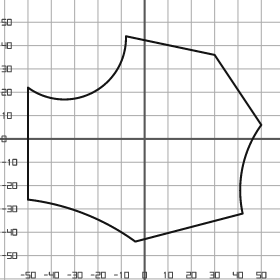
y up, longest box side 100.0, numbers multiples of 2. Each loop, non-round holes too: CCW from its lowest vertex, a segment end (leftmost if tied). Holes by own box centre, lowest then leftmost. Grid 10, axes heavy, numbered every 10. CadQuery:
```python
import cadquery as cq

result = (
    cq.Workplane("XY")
    .moveTo(-4.0, -44.0)
    .lineTo(42.0, -32.0)
    .threePointArc((42.0, -12.0), (50.0, 6.0))
    .lineTo(30.0, 36.0)
    .lineTo(-8.0, 44.0)
    .threePointArc((-22.0, 20.0), (-50.0, 22.0))
    .lineTo(-50.0, -26.0)
    .threePointArc((-26.0, -32.0), (-4.0, -44.0))
    .close()
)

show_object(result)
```